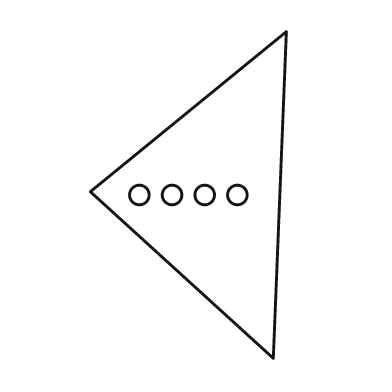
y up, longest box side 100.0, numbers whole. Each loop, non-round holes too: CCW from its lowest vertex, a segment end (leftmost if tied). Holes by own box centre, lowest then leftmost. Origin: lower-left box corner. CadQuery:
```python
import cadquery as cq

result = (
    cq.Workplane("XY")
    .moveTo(56.0, 0.0)
    .lineTo(60.0, 100.0)
    .lineTo(0.0, 51.0)
    .close()
    .moveTo(15.0, 50.0)
    .circle(3.0)
    .moveTo(25.0, 50.0)
    .circle(3.0)
    .moveTo(35.0, 50.0)
    .circle(3.0)
    .moveTo(45.0, 50.0)
    .circle(3.0)
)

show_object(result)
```